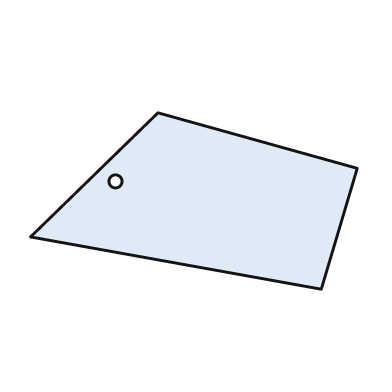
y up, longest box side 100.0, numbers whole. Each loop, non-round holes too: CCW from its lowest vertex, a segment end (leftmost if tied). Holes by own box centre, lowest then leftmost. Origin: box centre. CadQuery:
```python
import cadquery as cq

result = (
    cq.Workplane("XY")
    .moveTo(39.0, -27.0)
    .lineTo(50.0, 10.0)
    .lineTo(-11.0, 27.0)
    .lineTo(-50.0, -11.0)
    .close()
    .moveTo(-24.0, 6.0)
    .circle(2.0)
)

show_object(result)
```